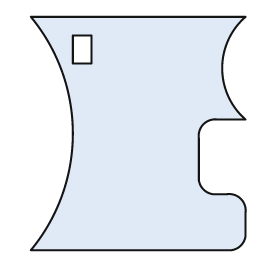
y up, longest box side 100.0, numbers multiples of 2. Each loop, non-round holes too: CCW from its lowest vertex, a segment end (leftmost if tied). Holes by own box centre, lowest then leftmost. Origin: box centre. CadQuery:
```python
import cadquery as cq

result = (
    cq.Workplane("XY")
    .moveTo(-46.0, -50.0)
    .lineTo(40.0, -50.0)
    .threePointArc((44.0, -48.0), (46.0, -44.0))
    .lineTo(46.0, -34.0)
    .threePointArc((44.0, -28.0), (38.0, -26.0))
    .lineTo(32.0, -26.0)
    .threePointArc((28.0, -24.0), (26.0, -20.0))
    .lineTo(26.0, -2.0)
    .threePointArc((28.0, 4.0), (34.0, 6.0))
    .lineTo(46.0, 6.0)
    .threePointArc((36.0, 28.0), (46.0, 50.0))
    .lineTo(-46.0, 50.0)
    .threePointArc((-28.0, 0.0), (-46.0, -50.0))
    .close()
    .moveTo(-28.0, 30.0)
    .lineTo(-20.0, 30.0)
    .lineTo(-20.0, 42.0)
    .lineTo(-28.0, 42.0)
    .close()
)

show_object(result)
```